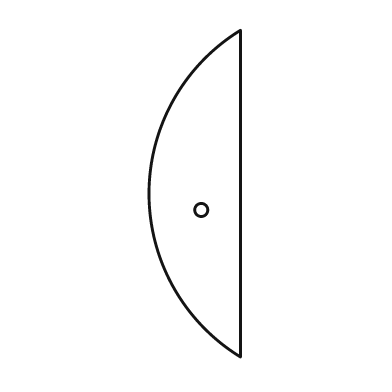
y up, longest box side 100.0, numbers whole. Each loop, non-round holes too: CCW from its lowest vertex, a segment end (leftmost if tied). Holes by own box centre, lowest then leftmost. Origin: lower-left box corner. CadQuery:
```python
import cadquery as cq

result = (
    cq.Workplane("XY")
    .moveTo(28.0, 0.0)
    .lineTo(28.0, 100.0)
    .threePointArc((0.0, 50.0), (28.0, 0.0))
    .close()
    .moveTo(16.0, 45.0)
    .circle(2.0)
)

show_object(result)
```